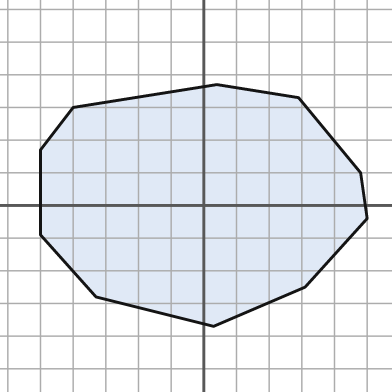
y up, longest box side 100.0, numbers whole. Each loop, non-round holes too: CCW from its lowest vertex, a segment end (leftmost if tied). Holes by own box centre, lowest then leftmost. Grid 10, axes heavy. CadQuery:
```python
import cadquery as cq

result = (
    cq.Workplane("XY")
    .moveTo(3.0, -37.0)
    .lineTo(31.0, -25.0)
    .lineTo(50.0, -4.0)
    .lineTo(48.0, 10.0)
    .lineTo(29.0, 33.0)
    .lineTo(4.0, 37.0)
    .lineTo(-40.0, 30.0)
    .lineTo(-50.0, 17.0)
    .lineTo(-50.0, -9.0)
    .lineTo(-33.0, -28.0)
    .close()
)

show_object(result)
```